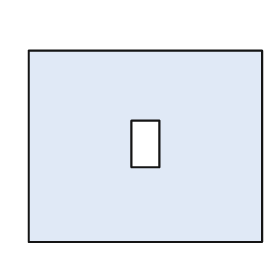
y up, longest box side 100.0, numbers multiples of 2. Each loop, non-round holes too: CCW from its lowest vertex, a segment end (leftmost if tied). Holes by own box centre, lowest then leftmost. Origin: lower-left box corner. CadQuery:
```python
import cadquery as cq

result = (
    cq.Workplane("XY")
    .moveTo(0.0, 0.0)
    .lineTo(100.0, 0.0)
    .lineTo(100.0, 82.0)
    .lineTo(0.0, 82.0)
    .close()
    .moveTo(44.0, 32.0)
    .lineTo(56.0, 32.0)
    .lineTo(56.0, 52.0)
    .lineTo(44.0, 52.0)
    .close()
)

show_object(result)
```